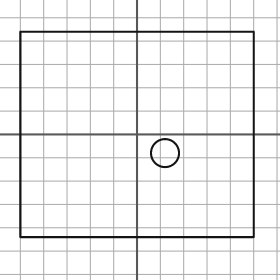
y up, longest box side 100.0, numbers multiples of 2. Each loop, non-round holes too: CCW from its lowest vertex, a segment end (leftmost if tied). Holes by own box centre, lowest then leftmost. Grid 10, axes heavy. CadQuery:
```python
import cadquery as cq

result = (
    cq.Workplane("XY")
    .moveTo(-50.0, -44.0)
    .lineTo(50.0, -44.0)
    .lineTo(50.0, 44.0)
    .lineTo(-50.0, 44.0)
    .close()
    .moveTo(12.0, -8.0)
    .circle(6.0)
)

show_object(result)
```